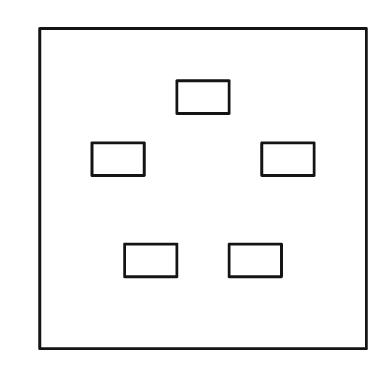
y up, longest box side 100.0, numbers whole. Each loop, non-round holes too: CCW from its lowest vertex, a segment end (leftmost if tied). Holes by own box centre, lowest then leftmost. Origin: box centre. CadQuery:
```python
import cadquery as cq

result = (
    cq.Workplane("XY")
    .moveTo(-50.0, -49.0)
    .lineTo(50.0, -49.0)
    .lineTo(50.0, 49.0)
    .lineTo(-50.0, 49.0)
    .close()
    .moveTo(-24.0, -27.0)
    .lineTo(-8.0, -27.0)
    .lineTo(-8.0, -17.0)
    .lineTo(-24.0, -17.0)
    .close()
    .moveTo(8.0, -27.0)
    .lineTo(24.0, -27.0)
    .lineTo(24.0, -17.0)
    .lineTo(8.0, -17.0)
    .close()
    .moveTo(-34.0, 4.0)
    .lineTo(-18.0, 4.0)
    .lineTo(-18.0, 14.0)
    .lineTo(-34.0, 14.0)
    .close()
    .moveTo(18.0, 4.0)
    .lineTo(34.0, 4.0)
    .lineTo(34.0, 14.0)
    .lineTo(18.0, 14.0)
    .close()
    .moveTo(-8.0, 23.0)
    .lineTo(8.0, 23.0)
    .lineTo(8.0, 33.0)
    .lineTo(-8.0, 33.0)
    .close()
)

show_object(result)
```